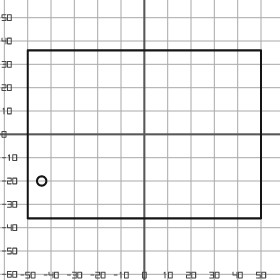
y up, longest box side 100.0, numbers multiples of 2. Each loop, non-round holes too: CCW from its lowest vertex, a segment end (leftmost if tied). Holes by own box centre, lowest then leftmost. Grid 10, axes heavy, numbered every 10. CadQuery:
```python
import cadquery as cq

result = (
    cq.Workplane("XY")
    .moveTo(-50.0, -36.0)
    .lineTo(50.0, -36.0)
    .lineTo(50.0, 36.0)
    .lineTo(-50.0, 36.0)
    .close()
    .moveTo(-44.0, -20.0)
    .circle(2.0)
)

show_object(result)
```